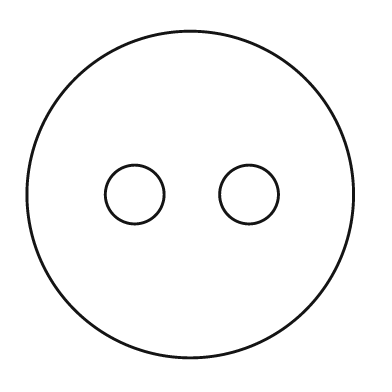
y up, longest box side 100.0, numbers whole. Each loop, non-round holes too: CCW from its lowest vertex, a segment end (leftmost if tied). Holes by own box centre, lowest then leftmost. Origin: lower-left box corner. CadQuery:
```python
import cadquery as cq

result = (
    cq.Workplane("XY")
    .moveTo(50.0, 50.0)
    .circle(50.0)
    .moveTo(33.0, 50.0)
    .circle(9.0)
    .moveTo(68.0, 50.0)
    .circle(9.0)
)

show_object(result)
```